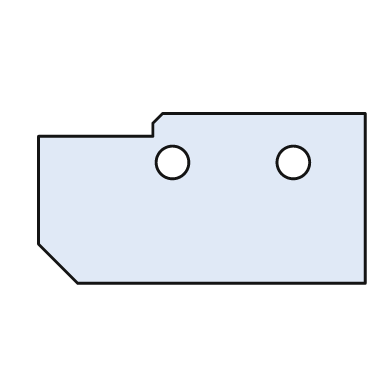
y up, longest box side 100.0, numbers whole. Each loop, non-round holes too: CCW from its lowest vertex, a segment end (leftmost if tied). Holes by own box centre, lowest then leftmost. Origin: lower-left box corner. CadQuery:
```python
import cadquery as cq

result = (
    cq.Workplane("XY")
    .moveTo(12.0, 0.0)
    .lineTo(100.0, 0.0)
    .lineTo(100.0, 52.0)
    .lineTo(38.0, 52.0)
    .lineTo(35.0, 49.0)
    .lineTo(35.0, 45.0)
    .lineTo(0.0, 45.0)
    .lineTo(0.0, 12.0)
    .close()
    .moveTo(41.0, 37.0)
    .circle(5.0)
    .moveTo(78.0, 37.0)
    .circle(5.0)
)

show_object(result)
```